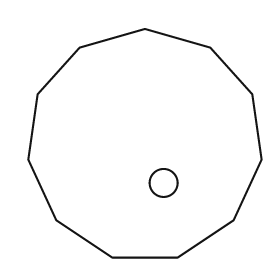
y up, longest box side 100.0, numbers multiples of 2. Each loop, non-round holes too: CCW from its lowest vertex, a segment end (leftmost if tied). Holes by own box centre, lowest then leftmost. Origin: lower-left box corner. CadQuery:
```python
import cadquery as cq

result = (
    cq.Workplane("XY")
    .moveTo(36.0, 0.0)
    .lineTo(64.0, 0.0)
    .lineTo(88.0, 16.0)
    .lineTo(100.0, 42.0)
    .lineTo(96.0, 70.0)
    .lineTo(78.0, 90.0)
    .lineTo(50.0, 98.0)
    .lineTo(22.0, 90.0)
    .lineTo(4.0, 70.0)
    .lineTo(0.0, 42.0)
    .lineTo(12.0, 16.0)
    .close()
    .moveTo(58.0, 32.0)
    .circle(6.0)
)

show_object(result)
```